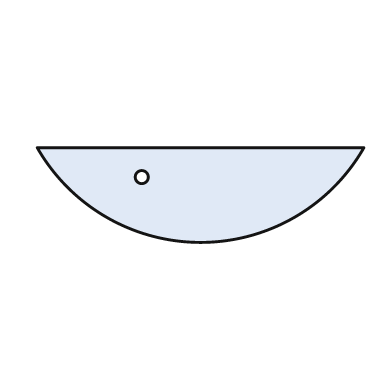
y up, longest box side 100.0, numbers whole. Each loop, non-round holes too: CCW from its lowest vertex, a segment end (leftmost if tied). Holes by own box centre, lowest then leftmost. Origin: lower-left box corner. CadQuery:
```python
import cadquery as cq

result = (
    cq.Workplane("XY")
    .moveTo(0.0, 29.0)
    .threePointArc((50.0, 0.0), (100.0, 29.0))
    .close()
    .moveTo(32.0, 20.0)
    .circle(2.0)
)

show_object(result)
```